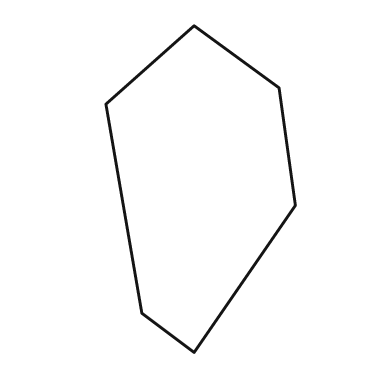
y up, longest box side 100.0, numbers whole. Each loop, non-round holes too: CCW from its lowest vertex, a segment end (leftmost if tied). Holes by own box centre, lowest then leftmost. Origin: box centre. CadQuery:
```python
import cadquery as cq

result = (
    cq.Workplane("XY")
    .moveTo(-2.0, -50.0)
    .lineTo(29.0, -5.0)
    .lineTo(24.0, 31.0)
    .lineTo(-2.0, 50.0)
    .lineTo(-29.0, 26.0)
    .lineTo(-18.0, -38.0)
    .close()
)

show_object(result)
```